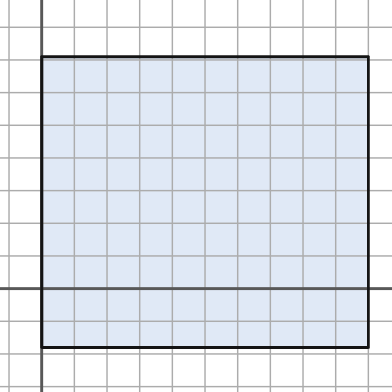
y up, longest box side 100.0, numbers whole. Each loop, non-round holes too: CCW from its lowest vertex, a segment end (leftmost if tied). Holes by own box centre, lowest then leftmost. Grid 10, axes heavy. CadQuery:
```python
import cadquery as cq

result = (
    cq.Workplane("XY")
    .moveTo(0.0, -18.0)
    .lineTo(100.0, -18.0)
    .lineTo(100.0, 71.0)
    .lineTo(0.0, 71.0)
    .close()
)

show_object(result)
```